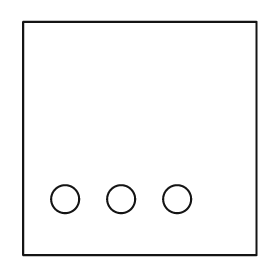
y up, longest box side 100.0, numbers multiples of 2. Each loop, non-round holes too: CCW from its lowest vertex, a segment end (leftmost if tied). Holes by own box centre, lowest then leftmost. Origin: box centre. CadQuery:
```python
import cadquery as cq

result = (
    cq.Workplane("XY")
    .moveTo(-50.0, -50.0)
    .lineTo(50.0, -50.0)
    .lineTo(50.0, 50.0)
    .lineTo(-50.0, 50.0)
    .close()
    .moveTo(-32.0, -26.0)
    .circle(6.0)
    .moveTo(-8.0, -26.0)
    .circle(6.0)
    .moveTo(16.0, -26.0)
    .circle(6.0)
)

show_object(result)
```